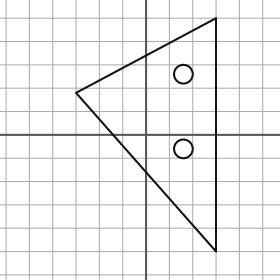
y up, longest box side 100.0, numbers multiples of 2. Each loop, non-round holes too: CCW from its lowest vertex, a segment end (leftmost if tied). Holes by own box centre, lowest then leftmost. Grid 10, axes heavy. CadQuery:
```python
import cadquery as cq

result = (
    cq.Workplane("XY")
    .moveTo(30.0, -50.0)
    .lineTo(30.0, 50.0)
    .lineTo(-30.0, 18.0)
    .close()
    .moveTo(16.0, -6.0)
    .circle(4.0)
    .moveTo(16.0, 26.0)
    .circle(4.0)
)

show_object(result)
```